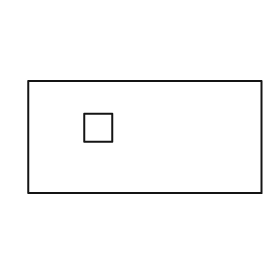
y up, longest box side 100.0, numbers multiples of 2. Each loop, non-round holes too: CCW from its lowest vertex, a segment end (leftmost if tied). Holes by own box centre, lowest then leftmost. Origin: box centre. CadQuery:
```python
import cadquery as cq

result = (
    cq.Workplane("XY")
    .moveTo(-50.0, -24.0)
    .lineTo(50.0, -24.0)
    .lineTo(50.0, 24.0)
    .lineTo(-50.0, 24.0)
    .close()
    .moveTo(-26.0, -2.0)
    .lineTo(-14.0, -2.0)
    .lineTo(-14.0, 10.0)
    .lineTo(-26.0, 10.0)
    .close()
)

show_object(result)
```